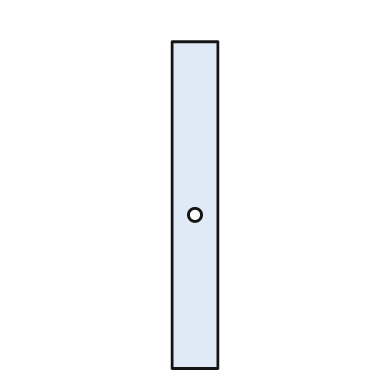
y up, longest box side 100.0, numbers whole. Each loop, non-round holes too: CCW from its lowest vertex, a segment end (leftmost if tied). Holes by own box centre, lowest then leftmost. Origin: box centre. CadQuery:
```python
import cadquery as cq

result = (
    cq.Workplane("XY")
    .moveTo(-7.0, -50.0)
    .lineTo(7.0, -50.0)
    .lineTo(7.0, 50.0)
    .lineTo(-7.0, 50.0)
    .close()
    .moveTo(0.0, -3.0)
    .circle(2.0)
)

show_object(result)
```